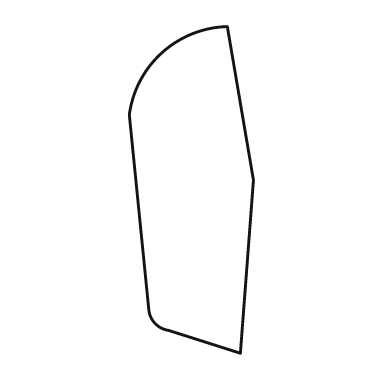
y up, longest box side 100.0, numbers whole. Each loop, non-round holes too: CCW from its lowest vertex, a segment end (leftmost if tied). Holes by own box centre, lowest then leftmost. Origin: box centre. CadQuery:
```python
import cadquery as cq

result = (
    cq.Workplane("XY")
    .moveTo(15.0, -50.0)
    .lineTo(19.0, 3.0)
    .lineTo(11.0, 50.0)
    .threePointArc((-9.0, 42.0), (-19.0, 23.0))
    .lineTo(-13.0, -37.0)
    .threePointArc((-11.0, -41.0), (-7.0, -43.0))
    .close()
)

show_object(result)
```